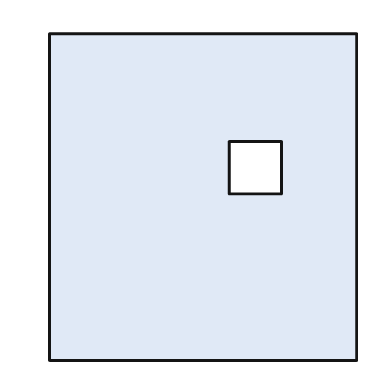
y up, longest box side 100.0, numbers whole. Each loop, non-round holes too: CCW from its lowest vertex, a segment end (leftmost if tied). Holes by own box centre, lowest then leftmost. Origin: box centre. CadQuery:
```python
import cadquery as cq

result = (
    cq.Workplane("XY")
    .moveTo(-47.0, -50.0)
    .lineTo(47.0, -50.0)
    .lineTo(47.0, 50.0)
    .lineTo(-47.0, 50.0)
    .close()
    .moveTo(8.0, 1.0)
    .lineTo(24.0, 1.0)
    .lineTo(24.0, 17.0)
    .lineTo(8.0, 17.0)
    .close()
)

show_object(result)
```